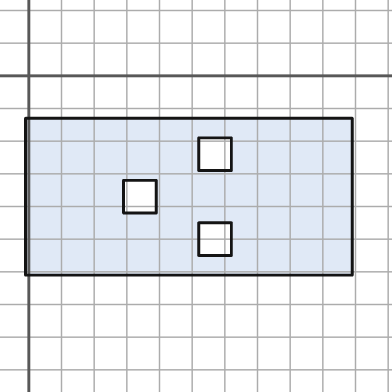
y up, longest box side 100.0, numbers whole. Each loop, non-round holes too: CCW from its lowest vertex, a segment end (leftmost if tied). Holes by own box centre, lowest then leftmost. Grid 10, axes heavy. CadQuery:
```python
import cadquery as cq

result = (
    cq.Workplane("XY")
    .moveTo(-1.0, -61.0)
    .lineTo(99.0, -61.0)
    .lineTo(99.0, -13.0)
    .lineTo(-1.0, -13.0)
    .close()
    .moveTo(52.0, -55.0)
    .lineTo(62.0, -55.0)
    .lineTo(62.0, -45.0)
    .lineTo(52.0, -45.0)
    .close()
    .moveTo(29.0, -42.0)
    .lineTo(39.0, -42.0)
    .lineTo(39.0, -32.0)
    .lineTo(29.0, -32.0)
    .close()
    .moveTo(52.0, -29.0)
    .lineTo(62.0, -29.0)
    .lineTo(62.0, -19.0)
    .lineTo(52.0, -19.0)
    .close()
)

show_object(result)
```